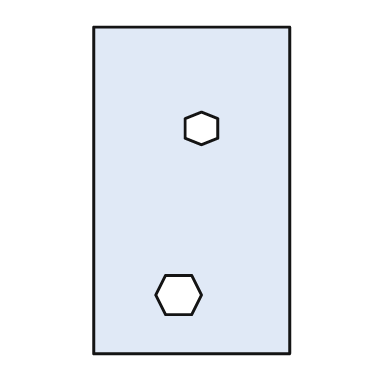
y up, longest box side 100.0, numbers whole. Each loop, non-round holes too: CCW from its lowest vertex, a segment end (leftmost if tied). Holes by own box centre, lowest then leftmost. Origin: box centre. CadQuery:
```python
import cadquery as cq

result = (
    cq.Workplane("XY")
    .moveTo(-30.0, -50.0)
    .lineTo(30.0, -50.0)
    .lineTo(30.0, 50.0)
    .lineTo(-30.0, 50.0)
    .close()
    .moveTo(-8.0, -38.0)
    .lineTo(0.0, -38.0)
    .lineTo(3.0, -32.0)
    .lineTo(0.0, -26.0)
    .lineTo(-8.0, -26.0)
    .lineTo(-11.0, -32.0)
    .close()
    .moveTo(3.0, 14.0)
    .lineTo(8.0, 16.0)
    .lineTo(8.0, 22.0)
    .lineTo(3.0, 24.0)
    .lineTo(-2.0, 22.0)
    .lineTo(-2.0, 16.0)
    .close()
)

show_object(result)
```